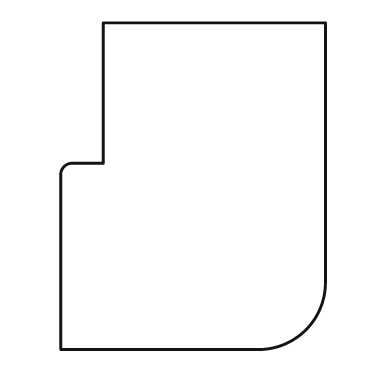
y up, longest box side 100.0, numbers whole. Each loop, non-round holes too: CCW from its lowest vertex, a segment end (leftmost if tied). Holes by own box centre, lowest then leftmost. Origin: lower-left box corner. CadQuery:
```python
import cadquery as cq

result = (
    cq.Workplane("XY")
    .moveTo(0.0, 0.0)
    .lineTo(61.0, 0.0)
    .threePointArc((75.0, 6.0), (81.0, 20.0))
    .lineTo(81.0, 100.0)
    .lineTo(13.0, 100.0)
    .lineTo(13.0, 57.0)
    .lineTo(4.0, 57.0)
    .threePointArc((1.0, 56.0), (0.0, 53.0))
    .close()
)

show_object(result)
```